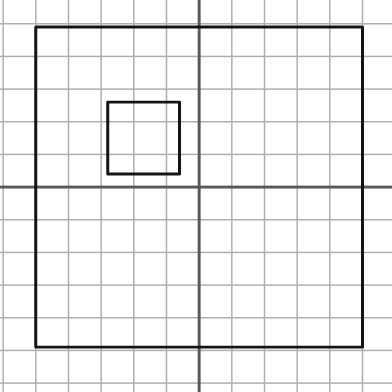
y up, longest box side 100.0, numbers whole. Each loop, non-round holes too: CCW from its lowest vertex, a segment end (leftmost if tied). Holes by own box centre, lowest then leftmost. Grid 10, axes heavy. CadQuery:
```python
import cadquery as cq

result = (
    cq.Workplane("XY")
    .moveTo(-50.0, -49.0)
    .lineTo(50.0, -49.0)
    .lineTo(50.0, 49.0)
    .lineTo(-50.0, 49.0)
    .close()
    .moveTo(-28.0, 4.0)
    .lineTo(-6.0, 4.0)
    .lineTo(-6.0, 26.0)
    .lineTo(-28.0, 26.0)
    .close()
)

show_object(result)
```